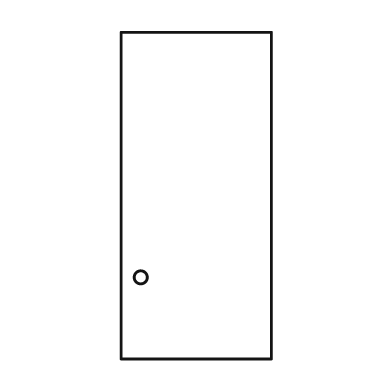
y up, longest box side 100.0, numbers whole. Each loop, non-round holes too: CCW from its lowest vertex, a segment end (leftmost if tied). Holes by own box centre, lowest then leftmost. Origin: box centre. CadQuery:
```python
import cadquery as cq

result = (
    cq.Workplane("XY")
    .moveTo(-23.0, -50.0)
    .lineTo(23.0, -50.0)
    .lineTo(23.0, 50.0)
    .lineTo(-23.0, 50.0)
    .close()
    .moveTo(-17.0, -25.0)
    .circle(2.0)
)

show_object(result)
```